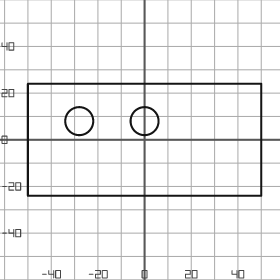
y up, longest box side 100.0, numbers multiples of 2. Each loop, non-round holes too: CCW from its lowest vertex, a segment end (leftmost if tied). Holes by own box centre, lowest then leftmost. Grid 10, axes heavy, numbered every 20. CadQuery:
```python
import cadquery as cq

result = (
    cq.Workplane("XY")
    .moveTo(-50.0, -24.0)
    .lineTo(50.0, -24.0)
    .lineTo(50.0, 24.0)
    .lineTo(-50.0, 24.0)
    .close()
    .moveTo(-28.0, 8.0)
    .circle(6.0)
    .moveTo(0.0, 8.0)
    .circle(6.0)
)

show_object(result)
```